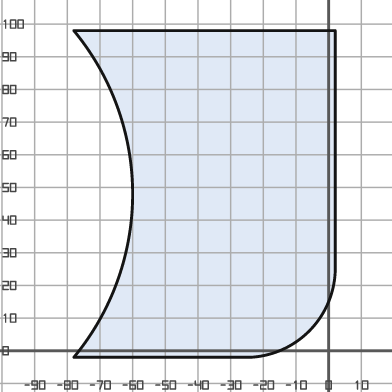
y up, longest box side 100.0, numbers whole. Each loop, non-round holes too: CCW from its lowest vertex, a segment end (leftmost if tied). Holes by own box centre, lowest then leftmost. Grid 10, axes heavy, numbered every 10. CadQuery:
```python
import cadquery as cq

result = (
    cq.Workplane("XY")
    .moveTo(-78.0, -2.0)
    .lineTo(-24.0, -2.0)
    .threePointArc((-6.0, 6.0), (2.0, 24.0))
    .lineTo(2.0, 98.0)
    .lineTo(-78.0, 98.0)
    .threePointArc((-60.0, 48.0), (-78.0, -2.0))
    .close()
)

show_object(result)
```